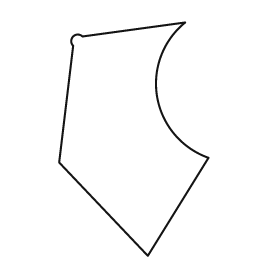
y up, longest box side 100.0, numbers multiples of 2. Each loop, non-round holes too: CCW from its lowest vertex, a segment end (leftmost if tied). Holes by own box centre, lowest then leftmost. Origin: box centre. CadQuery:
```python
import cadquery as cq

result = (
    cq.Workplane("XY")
    .moveTo(6.0, -50.0)
    .lineTo(32.0, -8.0)
    .threePointArc((10.0, 18.0), (22.0, 50.0))
    .lineTo(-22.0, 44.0)
    .threePointArc((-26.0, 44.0), (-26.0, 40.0))
    .lineTo(-32.0, -10.0)
    .close()
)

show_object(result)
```